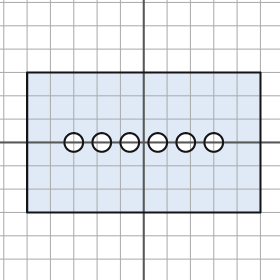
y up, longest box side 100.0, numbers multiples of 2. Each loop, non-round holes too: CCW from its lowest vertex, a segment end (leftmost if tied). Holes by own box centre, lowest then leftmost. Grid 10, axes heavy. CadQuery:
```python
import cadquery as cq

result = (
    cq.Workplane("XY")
    .moveTo(-50.0, -30.0)
    .lineTo(50.0, -30.0)
    .lineTo(50.0, 30.0)
    .lineTo(-50.0, 30.0)
    .close()
    .moveTo(-30.0, 0.0)
    .circle(4.0)
    .moveTo(-18.0, 0.0)
    .circle(4.0)
    .moveTo(-6.0, 0.0)
    .circle(4.0)
    .moveTo(6.0, 0.0)
    .circle(4.0)
    .moveTo(18.0, 0.0)
    .circle(4.0)
    .moveTo(30.0, 0.0)
    .circle(4.0)
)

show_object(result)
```